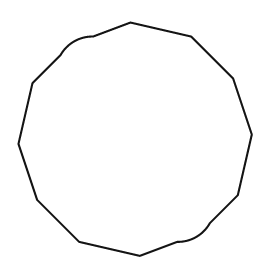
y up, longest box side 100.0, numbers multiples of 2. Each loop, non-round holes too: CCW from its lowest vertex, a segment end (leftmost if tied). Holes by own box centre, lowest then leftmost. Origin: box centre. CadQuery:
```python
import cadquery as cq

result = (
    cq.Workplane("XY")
    .moveTo(2.0, -50.0)
    .lineTo(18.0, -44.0)
    .threePointArc((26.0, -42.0), (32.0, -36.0))
    .lineTo(44.0, -24.0)
    .lineTo(50.0, 2.0)
    .lineTo(42.0, 26.0)
    .lineTo(24.0, 44.0)
    .lineTo(-2.0, 50.0)
    .lineTo(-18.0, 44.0)
    .threePointArc((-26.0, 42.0), (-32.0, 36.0))
    .lineTo(-44.0, 24.0)
    .lineTo(-50.0, -2.0)
    .lineTo(-42.0, -26.0)
    .lineTo(-24.0, -44.0)
    .close()
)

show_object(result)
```